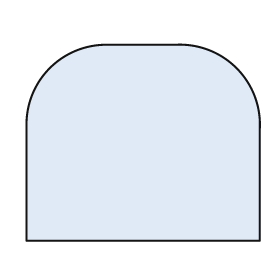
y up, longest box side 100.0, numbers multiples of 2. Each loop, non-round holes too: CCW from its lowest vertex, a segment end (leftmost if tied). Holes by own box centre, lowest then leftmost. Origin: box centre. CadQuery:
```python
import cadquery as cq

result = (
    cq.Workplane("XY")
    .moveTo(-50.0, -42.0)
    .lineTo(50.0, -42.0)
    .lineTo(50.0, 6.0)
    .threePointArc((40.0, 32.0), (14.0, 42.0))
    .lineTo(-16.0, 42.0)
    .threePointArc((-40.0, 32.0), (-50.0, 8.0))
    .close()
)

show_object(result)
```